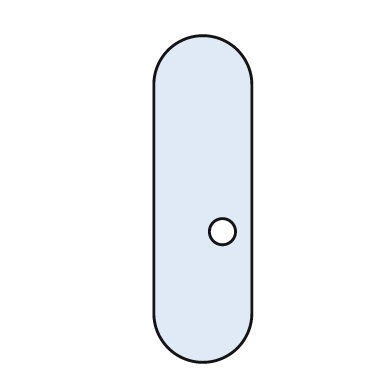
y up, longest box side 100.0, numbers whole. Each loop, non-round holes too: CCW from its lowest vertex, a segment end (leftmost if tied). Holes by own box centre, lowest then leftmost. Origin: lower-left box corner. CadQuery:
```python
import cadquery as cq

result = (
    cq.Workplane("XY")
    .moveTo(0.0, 15.0)
    .threePointArc((15.0, 0.0), (30.0, 15.0))
    .lineTo(30.0, 85.0)
    .threePointArc((15.0, 100.0), (0.0, 85.0))
    .close()
    .moveTo(21.0, 40.0)
    .circle(4.0)
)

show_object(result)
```